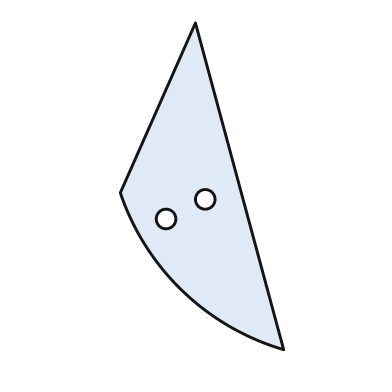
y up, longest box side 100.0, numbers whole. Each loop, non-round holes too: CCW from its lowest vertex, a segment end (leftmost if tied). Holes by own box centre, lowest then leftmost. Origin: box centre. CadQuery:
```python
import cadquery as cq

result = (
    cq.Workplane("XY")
    .moveTo(25.0, -50.0)
    .lineTo(-2.0, 50.0)
    .lineTo(-25.0, -2.0)
    .threePointArc((-6.0, -32.0), (25.0, -50.0))
    .close()
    .moveTo(-11.0, -10.0)
    .circle(3.0)
    .moveTo(1.0, -4.0)
    .circle(3.0)
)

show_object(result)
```